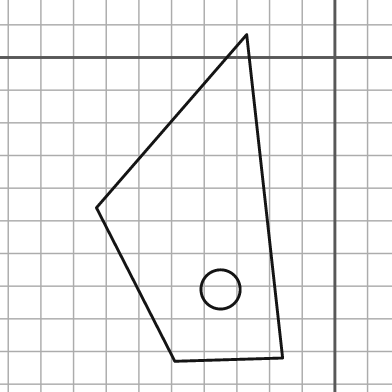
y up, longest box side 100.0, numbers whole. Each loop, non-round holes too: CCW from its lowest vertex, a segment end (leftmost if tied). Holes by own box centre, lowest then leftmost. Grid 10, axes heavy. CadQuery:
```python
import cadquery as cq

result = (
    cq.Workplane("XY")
    .moveTo(-49.0, -93.0)
    .lineTo(-16.0, -92.0)
    .lineTo(-27.0, 7.0)
    .lineTo(-73.0, -46.0)
    .close()
    .moveTo(-35.0, -71.0)
    .circle(6.0)
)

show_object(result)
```